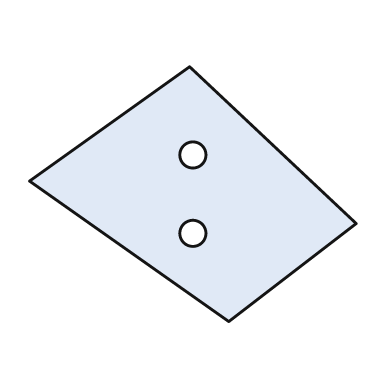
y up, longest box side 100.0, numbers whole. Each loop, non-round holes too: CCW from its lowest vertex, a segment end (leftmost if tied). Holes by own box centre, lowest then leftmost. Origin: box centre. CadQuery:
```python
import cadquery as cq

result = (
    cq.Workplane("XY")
    .moveTo(11.0, -39.0)
    .lineTo(50.0, -9.0)
    .lineTo(-1.0, 39.0)
    .lineTo(-50.0, 4.0)
    .close()
    .moveTo(0.0, -12.0)
    .circle(4.0)
    .moveTo(0.0, 12.0)
    .circle(4.0)
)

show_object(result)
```